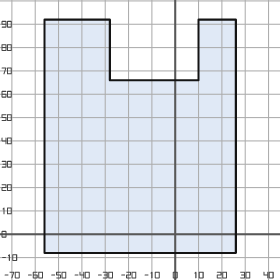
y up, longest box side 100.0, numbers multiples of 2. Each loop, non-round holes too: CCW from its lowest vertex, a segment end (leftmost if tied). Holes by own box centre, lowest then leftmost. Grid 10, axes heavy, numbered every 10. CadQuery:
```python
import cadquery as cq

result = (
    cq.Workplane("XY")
    .moveTo(-56.0, -8.0)
    .lineTo(26.0, -8.0)
    .lineTo(26.0, 92.0)
    .lineTo(10.0, 92.0)
    .lineTo(10.0, 66.0)
    .lineTo(-28.0, 66.0)
    .lineTo(-28.0, 92.0)
    .lineTo(-56.0, 92.0)
    .close()
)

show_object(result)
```